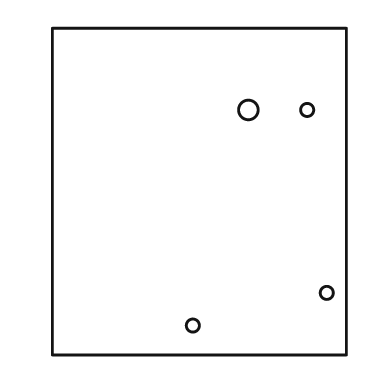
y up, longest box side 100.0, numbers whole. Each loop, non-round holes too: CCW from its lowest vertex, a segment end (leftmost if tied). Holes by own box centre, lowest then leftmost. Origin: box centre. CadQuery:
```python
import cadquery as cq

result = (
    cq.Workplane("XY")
    .moveTo(-45.0, -50.0)
    .lineTo(45.0, -50.0)
    .lineTo(45.0, 50.0)
    .lineTo(-45.0, 50.0)
    .close()
    .moveTo(-2.0, -41.0)
    .circle(2.0)
    .moveTo(39.0, -31.0)
    .circle(2.0)
    .moveTo(15.0, 25.0)
    .circle(3.0)
    .moveTo(33.0, 25.0)
    .circle(2.0)
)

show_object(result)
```